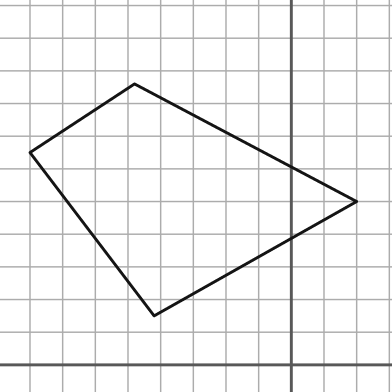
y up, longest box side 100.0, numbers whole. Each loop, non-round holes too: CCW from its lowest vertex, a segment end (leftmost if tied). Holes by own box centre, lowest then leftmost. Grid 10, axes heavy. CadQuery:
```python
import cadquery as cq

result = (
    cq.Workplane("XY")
    .moveTo(-42.0, 15.0)
    .lineTo(20.0, 50.0)
    .lineTo(-48.0, 86.0)
    .lineTo(-80.0, 65.0)
    .close()
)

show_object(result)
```